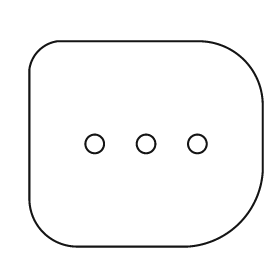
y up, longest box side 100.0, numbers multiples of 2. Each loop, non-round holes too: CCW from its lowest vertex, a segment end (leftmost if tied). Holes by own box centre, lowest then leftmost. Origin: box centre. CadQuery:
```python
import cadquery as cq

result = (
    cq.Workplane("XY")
    .moveTo(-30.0, -44.0)
    .lineTo(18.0, -44.0)
    .threePointArc((40.0, -34.0), (50.0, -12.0))
    .lineTo(50.0, 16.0)
    .threePointArc((42.0, 36.0), (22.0, 44.0))
    .lineTo(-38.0, 44.0)
    .threePointArc((-46.0, 40.0), (-50.0, 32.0))
    .lineTo(-50.0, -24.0)
    .threePointArc((-44.0, -38.0), (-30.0, -44.0))
    .close()
    .moveTo(-22.0, 0.0)
    .circle(4.0)
    .moveTo(0.0, 0.0)
    .circle(4.0)
    .moveTo(22.0, 0.0)
    .circle(4.0)
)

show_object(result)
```